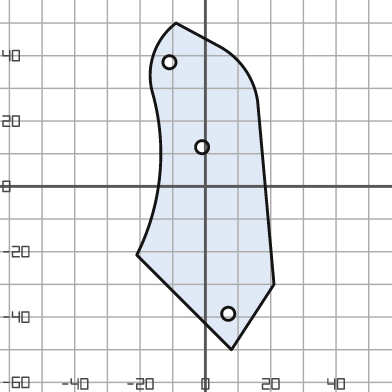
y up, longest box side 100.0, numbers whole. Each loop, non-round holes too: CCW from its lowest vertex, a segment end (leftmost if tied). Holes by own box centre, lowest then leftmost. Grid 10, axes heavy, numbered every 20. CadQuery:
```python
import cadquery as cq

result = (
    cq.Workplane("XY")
    .moveTo(8.0, -50.0)
    .lineTo(21.0, -30.0)
    .lineTo(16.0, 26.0)
    .threePointArc((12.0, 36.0), (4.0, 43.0))
    .lineTo(-9.0, 50.0)
    .threePointArc((-16.0, 40.0), (-16.0, 28.0))
    .threePointArc((-14.0, 3.0), (-21.0, -21.0))
    .close()
    .moveTo(7.0, -39.0)
    .circle(2.0)
    .moveTo(-1.0, 12.0)
    .circle(2.0)
    .moveTo(-11.0, 38.0)
    .circle(2.0)
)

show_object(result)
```